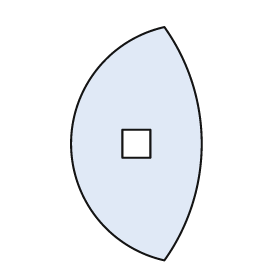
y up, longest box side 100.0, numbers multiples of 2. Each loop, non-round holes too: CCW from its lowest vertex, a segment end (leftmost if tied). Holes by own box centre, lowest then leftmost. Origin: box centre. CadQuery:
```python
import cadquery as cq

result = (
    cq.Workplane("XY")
    .moveTo(12.0, -50.0)
    .threePointArc((28.0, 0.0), (12.0, 50.0))
    .threePointArc((-28.0, 0.0), (12.0, -50.0))
    .close()
    .moveTo(-6.0, -6.0)
    .lineTo(6.0, -6.0)
    .lineTo(6.0, 6.0)
    .lineTo(-6.0, 6.0)
    .close()
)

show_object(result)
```